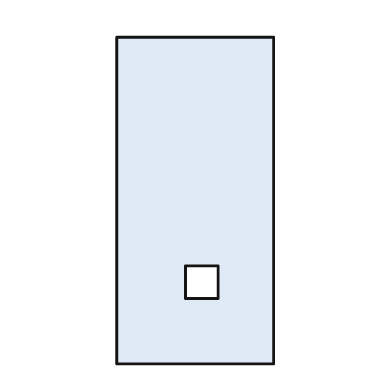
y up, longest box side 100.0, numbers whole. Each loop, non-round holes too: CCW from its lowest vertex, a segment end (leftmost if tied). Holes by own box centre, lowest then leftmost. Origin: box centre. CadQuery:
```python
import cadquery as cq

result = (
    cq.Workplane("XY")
    .moveTo(-24.0, -50.0)
    .lineTo(24.0, -50.0)
    .lineTo(24.0, 50.0)
    .lineTo(-24.0, 50.0)
    .close()
    .moveTo(-3.0, -30.0)
    .lineTo(7.0, -30.0)
    .lineTo(7.0, -20.0)
    .lineTo(-3.0, -20.0)
    .close()
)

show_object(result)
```